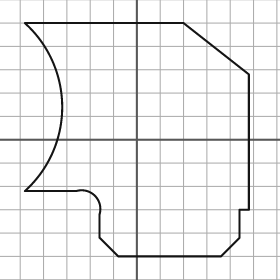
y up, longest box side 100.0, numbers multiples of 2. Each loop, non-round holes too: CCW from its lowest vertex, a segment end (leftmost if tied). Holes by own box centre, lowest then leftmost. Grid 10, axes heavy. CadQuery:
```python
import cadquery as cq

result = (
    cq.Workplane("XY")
    .moveTo(-8.0, -50.0)
    .lineTo(36.0, -50.0)
    .lineTo(44.0, -42.0)
    .lineTo(44.0, -30.0)
    .lineTo(48.0, -30.0)
    .lineTo(48.0, 28.0)
    .lineTo(20.0, 50.0)
    .lineTo(-48.0, 50.0)
    .threePointArc((-32.0, 14.0), (-48.0, -22.0))
    .lineTo(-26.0, -22.0)
    .threePointArc((-18.0, -24.0), (-16.0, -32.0))
    .lineTo(-16.0, -42.0)
    .close()
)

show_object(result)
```